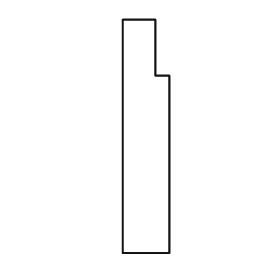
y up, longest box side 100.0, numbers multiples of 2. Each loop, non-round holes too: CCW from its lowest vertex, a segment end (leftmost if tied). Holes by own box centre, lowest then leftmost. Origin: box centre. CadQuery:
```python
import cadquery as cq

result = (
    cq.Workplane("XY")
    .moveTo(-10.0, -50.0)
    .lineTo(10.0, -50.0)
    .lineTo(10.0, 26.0)
    .lineTo(4.0, 26.0)
    .lineTo(4.0, 50.0)
    .lineTo(-10.0, 50.0)
    .close()
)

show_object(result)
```